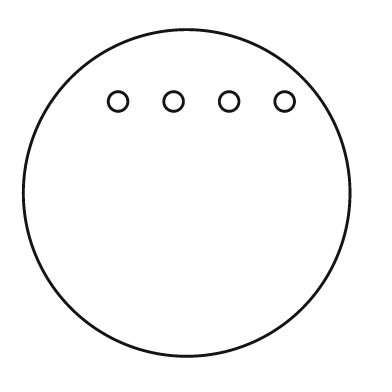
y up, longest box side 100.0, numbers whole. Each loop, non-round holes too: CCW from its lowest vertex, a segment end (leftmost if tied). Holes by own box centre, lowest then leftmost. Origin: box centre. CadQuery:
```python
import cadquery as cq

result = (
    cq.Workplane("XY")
    .moveTo(0.0, 0.0)
    .circle(50.0)
    .moveTo(-21.0, 28.0)
    .circle(3.0)
    .moveTo(-4.0, 28.0)
    .circle(3.0)
    .moveTo(13.0, 28.0)
    .circle(3.0)
    .moveTo(30.0, 28.0)
    .circle(3.0)
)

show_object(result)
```